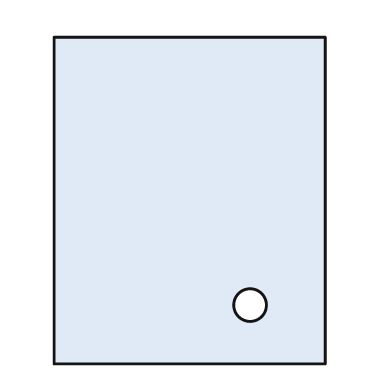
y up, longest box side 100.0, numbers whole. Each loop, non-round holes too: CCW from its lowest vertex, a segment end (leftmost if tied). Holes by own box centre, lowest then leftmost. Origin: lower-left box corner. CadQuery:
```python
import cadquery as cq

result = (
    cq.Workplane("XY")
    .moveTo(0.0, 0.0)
    .lineTo(83.0, 0.0)
    .lineTo(83.0, 100.0)
    .lineTo(0.0, 100.0)
    .close()
    .moveTo(60.0, 18.0)
    .circle(5.0)
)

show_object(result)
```